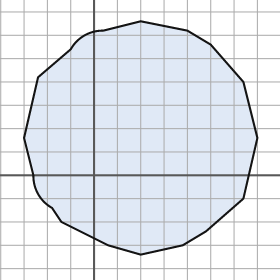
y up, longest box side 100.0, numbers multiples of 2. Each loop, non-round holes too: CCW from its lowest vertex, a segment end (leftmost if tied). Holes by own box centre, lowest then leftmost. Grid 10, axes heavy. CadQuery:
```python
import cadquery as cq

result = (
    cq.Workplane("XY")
    .moveTo(20.0, -34.0)
    .lineTo(38.0, -30.0)
    .lineTo(48.0, -24.0)
    .lineTo(64.0, -10.0)
    .lineTo(70.0, 16.0)
    .lineTo(64.0, 40.0)
    .lineTo(50.0, 56.0)
    .lineTo(40.0, 62.0)
    .lineTo(20.0, 66.0)
    .lineTo(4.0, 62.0)
    .threePointArc((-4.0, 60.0), (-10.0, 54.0))
    .lineTo(-24.0, 42.0)
    .lineTo(-30.0, 16.0)
    .lineTo(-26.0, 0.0)
    .threePointArc((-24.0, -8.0), (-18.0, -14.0))
    .lineTo(-14.0, -20.0)
    .lineTo(6.0, -30.0)
    .close()
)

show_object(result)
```